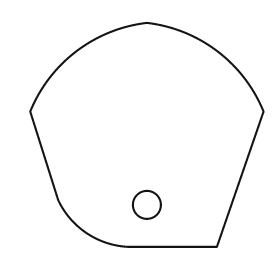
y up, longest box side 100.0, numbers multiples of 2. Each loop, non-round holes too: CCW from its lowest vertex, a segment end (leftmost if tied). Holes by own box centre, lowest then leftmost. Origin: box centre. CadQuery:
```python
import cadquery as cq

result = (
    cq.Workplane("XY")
    .moveTo(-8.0, -48.0)
    .lineTo(30.0, -48.0)
    .lineTo(50.0, 10.0)
    .threePointArc((30.0, 36.0), (0.0, 48.0))
    .threePointArc((-30.0, 36.0), (-50.0, 10.0))
    .lineTo(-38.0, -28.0)
    .threePointArc((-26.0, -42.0), (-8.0, -48.0))
    .close()
    .moveTo(0.0, -30.0)
    .circle(6.0)
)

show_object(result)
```